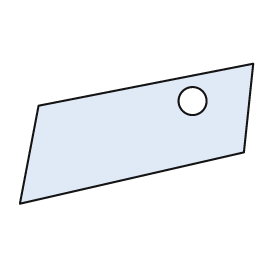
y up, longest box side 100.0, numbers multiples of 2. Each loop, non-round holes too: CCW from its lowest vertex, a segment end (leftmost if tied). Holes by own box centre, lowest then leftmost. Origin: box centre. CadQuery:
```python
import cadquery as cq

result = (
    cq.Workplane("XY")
    .moveTo(-50.0, -30.0)
    .lineTo(46.0, -8.0)
    .lineTo(50.0, 30.0)
    .lineTo(-42.0, 12.0)
    .close()
    .moveTo(24.0, 14.0)
    .circle(6.0)
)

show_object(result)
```